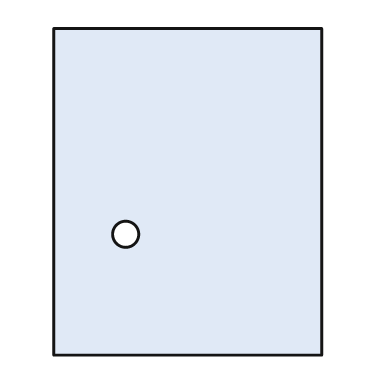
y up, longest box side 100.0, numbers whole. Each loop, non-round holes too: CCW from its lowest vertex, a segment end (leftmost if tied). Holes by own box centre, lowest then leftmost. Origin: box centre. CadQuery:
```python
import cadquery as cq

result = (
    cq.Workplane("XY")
    .moveTo(-41.0, -50.0)
    .lineTo(41.0, -50.0)
    .lineTo(41.0, 50.0)
    .lineTo(-41.0, 50.0)
    .close()
    .moveTo(-19.0, -13.0)
    .circle(4.0)
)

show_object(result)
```